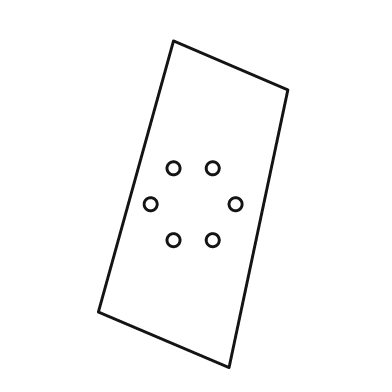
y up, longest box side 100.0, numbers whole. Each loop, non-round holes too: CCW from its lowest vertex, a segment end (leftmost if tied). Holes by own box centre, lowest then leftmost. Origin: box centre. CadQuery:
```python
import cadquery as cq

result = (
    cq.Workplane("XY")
    .moveTo(11.0, -50.0)
    .lineTo(29.0, 35.0)
    .lineTo(-6.0, 50.0)
    .lineTo(-29.0, -33.0)
    .close()
    .moveTo(-6.0, -11.0)
    .circle(2.0)
    .moveTo(6.0, -11.0)
    .circle(2.0)
    .moveTo(-13.0, 0.0)
    .circle(2.0)
    .moveTo(13.0, 0.0)
    .circle(2.0)
    .moveTo(-6.0, 11.0)
    .circle(2.0)
    .moveTo(6.0, 11.0)
    .circle(2.0)
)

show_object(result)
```